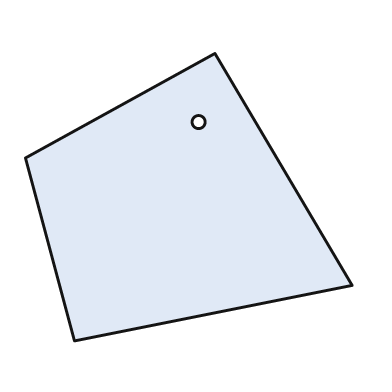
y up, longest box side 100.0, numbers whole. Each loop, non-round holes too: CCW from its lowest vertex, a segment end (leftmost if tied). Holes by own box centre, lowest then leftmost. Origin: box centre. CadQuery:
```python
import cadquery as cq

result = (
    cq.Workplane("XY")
    .moveTo(-35.0, -44.0)
    .lineTo(50.0, -27.0)
    .lineTo(8.0, 44.0)
    .lineTo(-50.0, 12.0)
    .close()
    .moveTo(3.0, 23.0)
    .circle(2.0)
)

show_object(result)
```